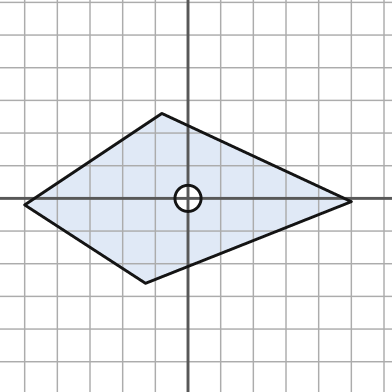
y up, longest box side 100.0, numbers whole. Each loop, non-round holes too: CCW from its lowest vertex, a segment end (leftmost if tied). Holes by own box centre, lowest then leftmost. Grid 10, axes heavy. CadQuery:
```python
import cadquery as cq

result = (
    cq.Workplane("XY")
    .moveTo(-13.0, -26.0)
    .lineTo(50.0, -1.0)
    .lineTo(-8.0, 26.0)
    .lineTo(-50.0, -2.0)
    .close()
    .moveTo(0.0, 0.0)
    .circle(4.0)
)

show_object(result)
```